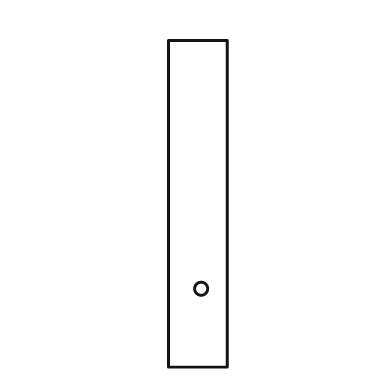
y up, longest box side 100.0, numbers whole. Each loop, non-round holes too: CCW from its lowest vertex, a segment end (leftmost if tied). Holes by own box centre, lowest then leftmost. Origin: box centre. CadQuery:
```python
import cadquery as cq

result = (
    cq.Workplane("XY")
    .moveTo(-9.0, -50.0)
    .lineTo(9.0, -50.0)
    .lineTo(9.0, 50.0)
    .lineTo(-9.0, 50.0)
    .close()
    .moveTo(1.0, -26.0)
    .circle(2.0)
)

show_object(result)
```